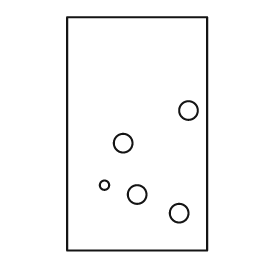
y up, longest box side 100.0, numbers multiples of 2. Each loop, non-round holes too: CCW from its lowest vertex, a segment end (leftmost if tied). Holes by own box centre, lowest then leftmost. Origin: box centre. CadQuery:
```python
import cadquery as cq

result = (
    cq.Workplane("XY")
    .moveTo(-30.0, -50.0)
    .lineTo(30.0, -50.0)
    .lineTo(30.0, 50.0)
    .lineTo(-30.0, 50.0)
    .close()
    .moveTo(18.0, -34.0)
    .circle(4.0)
    .moveTo(0.0, -26.0)
    .circle(4.0)
    .moveTo(-14.0, -22.0)
    .circle(2.0)
    .moveTo(-6.0, -4.0)
    .circle(4.0)
    .moveTo(22.0, 10.0)
    .circle(4.0)
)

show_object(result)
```